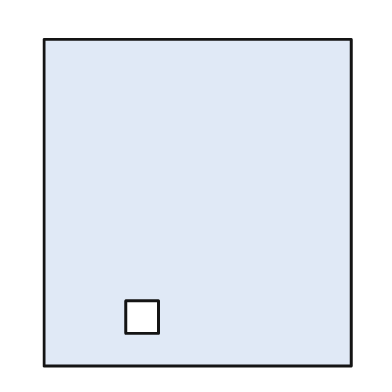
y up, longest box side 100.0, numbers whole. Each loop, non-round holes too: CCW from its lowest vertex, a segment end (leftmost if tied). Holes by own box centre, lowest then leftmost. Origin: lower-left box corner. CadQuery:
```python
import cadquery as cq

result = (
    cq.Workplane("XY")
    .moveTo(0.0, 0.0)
    .lineTo(94.0, 0.0)
    .lineTo(94.0, 100.0)
    .lineTo(0.0, 100.0)
    .close()
    .moveTo(25.0, 10.0)
    .lineTo(35.0, 10.0)
    .lineTo(35.0, 20.0)
    .lineTo(25.0, 20.0)
    .close()
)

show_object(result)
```